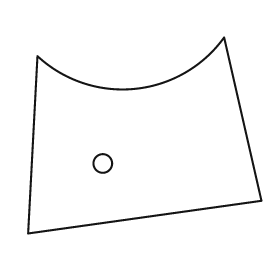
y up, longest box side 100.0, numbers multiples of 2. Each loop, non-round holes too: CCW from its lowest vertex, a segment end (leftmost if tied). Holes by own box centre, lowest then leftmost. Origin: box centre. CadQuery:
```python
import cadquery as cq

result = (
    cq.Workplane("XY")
    .moveTo(-50.0, -42.0)
    .lineTo(50.0, -28.0)
    .lineTo(34.0, 42.0)
    .threePointArc((-4.0, 20.0), (-46.0, 34.0))
    .close()
    .moveTo(-18.0, -12.0)
    .circle(4.0)
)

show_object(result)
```